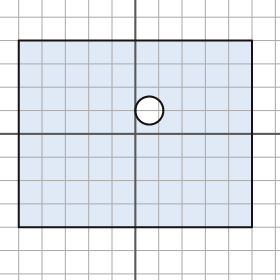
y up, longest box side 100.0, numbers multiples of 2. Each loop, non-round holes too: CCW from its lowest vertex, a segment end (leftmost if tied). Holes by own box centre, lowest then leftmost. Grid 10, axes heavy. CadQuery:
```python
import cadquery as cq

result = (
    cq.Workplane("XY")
    .moveTo(-50.0, -40.0)
    .lineTo(50.0, -40.0)
    .lineTo(50.0, 40.0)
    .lineTo(-50.0, 40.0)
    .close()
    .moveTo(6.0, 10.0)
    .circle(6.0)
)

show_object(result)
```